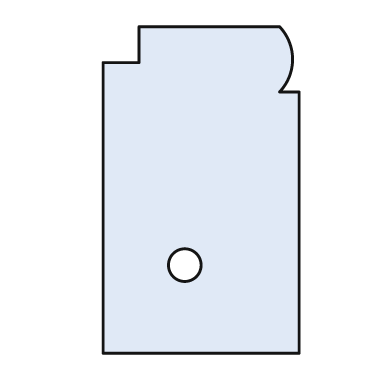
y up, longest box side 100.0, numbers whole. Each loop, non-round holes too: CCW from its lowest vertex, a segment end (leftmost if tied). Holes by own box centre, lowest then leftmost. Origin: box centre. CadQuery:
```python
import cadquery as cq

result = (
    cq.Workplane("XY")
    .moveTo(-30.0, -50.0)
    .lineTo(30.0, -50.0)
    .lineTo(30.0, 30.0)
    .lineTo(24.0, 30.0)
    .threePointArc((28.0, 40.0), (24.0, 50.0))
    .lineTo(-19.0, 50.0)
    .lineTo(-19.0, 39.0)
    .lineTo(-30.0, 39.0)
    .close()
    .moveTo(-5.0, -23.0)
    .circle(5.0)
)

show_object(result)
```